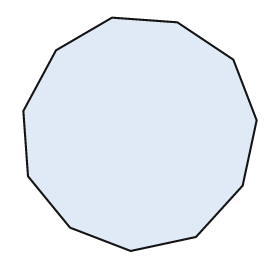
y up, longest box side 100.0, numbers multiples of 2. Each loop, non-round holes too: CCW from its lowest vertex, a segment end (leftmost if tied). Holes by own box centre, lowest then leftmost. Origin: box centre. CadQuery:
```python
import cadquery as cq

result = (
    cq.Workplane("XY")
    .moveTo(-4.0, -50.0)
    .lineTo(24.0, -44.0)
    .lineTo(44.0, -22.0)
    .lineTo(50.0, 6.0)
    .lineTo(40.0, 32.0)
    .lineTo(16.0, 48.0)
    .lineTo(-12.0, 50.0)
    .lineTo(-36.0, 36.0)
    .lineTo(-50.0, 10.0)
    .lineTo(-48.0, -18.0)
    .lineTo(-30.0, -40.0)
    .close()
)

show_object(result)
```